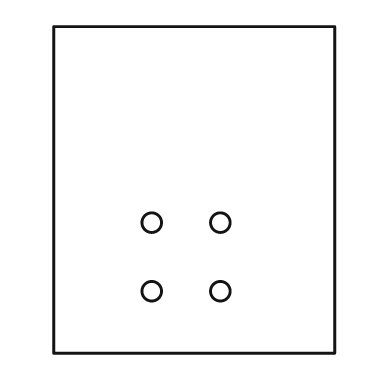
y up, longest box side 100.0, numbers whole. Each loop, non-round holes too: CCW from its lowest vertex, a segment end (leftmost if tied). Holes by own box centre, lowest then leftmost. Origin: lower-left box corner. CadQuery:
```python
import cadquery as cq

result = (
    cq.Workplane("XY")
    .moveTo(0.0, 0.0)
    .lineTo(86.0, 0.0)
    .lineTo(86.0, 100.0)
    .lineTo(0.0, 100.0)
    .close()
    .moveTo(30.0, 19.0)
    .circle(3.0)
    .moveTo(51.0, 19.0)
    .circle(3.0)
    .moveTo(30.0, 40.0)
    .circle(3.0)
    .moveTo(51.0, 40.0)
    .circle(3.0)
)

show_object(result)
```